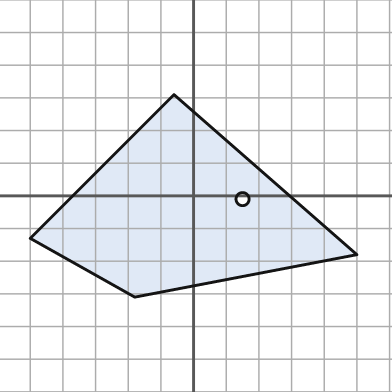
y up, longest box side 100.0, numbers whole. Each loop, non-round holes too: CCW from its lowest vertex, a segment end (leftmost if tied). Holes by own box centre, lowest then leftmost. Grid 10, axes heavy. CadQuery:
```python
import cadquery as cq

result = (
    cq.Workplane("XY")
    .moveTo(-18.0, -31.0)
    .lineTo(50.0, -18.0)
    .lineTo(-6.0, 31.0)
    .lineTo(-50.0, -13.0)
    .close()
    .moveTo(15.0, -1.0)
    .circle(2.0)
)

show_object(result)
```